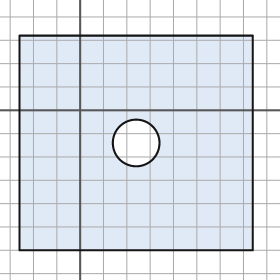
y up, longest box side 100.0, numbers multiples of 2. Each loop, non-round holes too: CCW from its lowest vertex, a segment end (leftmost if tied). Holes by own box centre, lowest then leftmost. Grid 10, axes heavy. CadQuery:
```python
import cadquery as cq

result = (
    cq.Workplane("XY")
    .moveTo(-26.0, -60.0)
    .lineTo(74.0, -60.0)
    .lineTo(74.0, 32.0)
    .lineTo(-26.0, 32.0)
    .close()
    .moveTo(24.0, -14.0)
    .circle(10.0)
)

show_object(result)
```